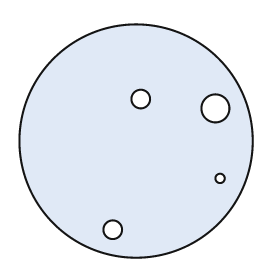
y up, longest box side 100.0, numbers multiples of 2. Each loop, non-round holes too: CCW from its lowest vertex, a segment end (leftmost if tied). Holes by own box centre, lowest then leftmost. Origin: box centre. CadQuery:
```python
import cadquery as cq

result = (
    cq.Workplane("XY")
    .moveTo(0.0, 0.0)
    .circle(50.0)
    .moveTo(-10.0, -38.0)
    .circle(4.0)
    .moveTo(36.0, -16.0)
    .circle(2.0)
    .moveTo(34.0, 14.0)
    .circle(6.0)
    .moveTo(2.0, 18.0)
    .circle(4.0)
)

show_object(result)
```